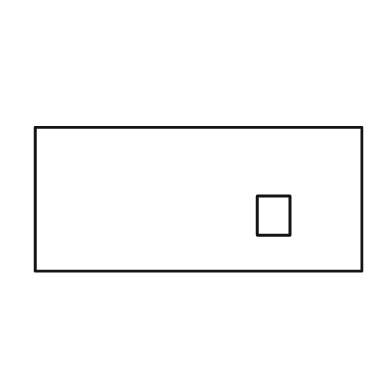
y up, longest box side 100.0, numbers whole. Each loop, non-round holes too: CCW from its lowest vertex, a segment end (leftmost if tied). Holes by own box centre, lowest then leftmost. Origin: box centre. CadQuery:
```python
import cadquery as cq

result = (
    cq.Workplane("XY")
    .moveTo(-50.0, -22.0)
    .lineTo(50.0, -22.0)
    .lineTo(50.0, 22.0)
    .lineTo(-50.0, 22.0)
    .close()
    .moveTo(18.0, -11.0)
    .lineTo(28.0, -11.0)
    .lineTo(28.0, 1.0)
    .lineTo(18.0, 1.0)
    .close()
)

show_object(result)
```